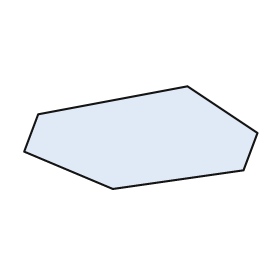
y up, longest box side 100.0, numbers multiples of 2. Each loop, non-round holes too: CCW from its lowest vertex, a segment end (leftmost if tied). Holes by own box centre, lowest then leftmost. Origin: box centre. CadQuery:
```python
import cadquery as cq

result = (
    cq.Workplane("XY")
    .moveTo(-12.0, -22.0)
    .lineTo(44.0, -14.0)
    .lineTo(50.0, 2.0)
    .lineTo(20.0, 22.0)
    .lineTo(-44.0, 10.0)
    .lineTo(-50.0, -6.0)
    .close()
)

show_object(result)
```